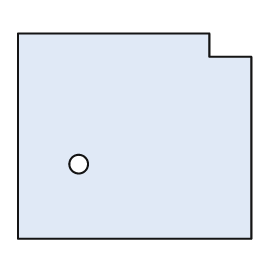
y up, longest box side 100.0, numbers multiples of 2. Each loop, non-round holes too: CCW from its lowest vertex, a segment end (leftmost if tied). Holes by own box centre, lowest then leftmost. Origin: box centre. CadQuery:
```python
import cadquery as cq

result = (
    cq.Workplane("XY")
    .moveTo(-50.0, -44.0)
    .lineTo(50.0, -44.0)
    .lineTo(50.0, 34.0)
    .lineTo(32.0, 34.0)
    .lineTo(32.0, 44.0)
    .lineTo(-50.0, 44.0)
    .close()
    .moveTo(-24.0, -12.0)
    .circle(4.0)
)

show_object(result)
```